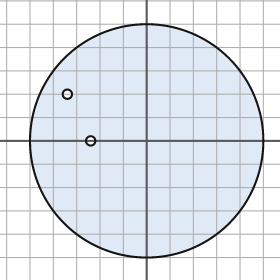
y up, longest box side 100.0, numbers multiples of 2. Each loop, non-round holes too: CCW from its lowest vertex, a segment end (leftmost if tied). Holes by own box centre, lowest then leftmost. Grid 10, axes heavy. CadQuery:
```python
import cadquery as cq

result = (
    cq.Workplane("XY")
    .moveTo(0.0, 0.0)
    .circle(50.0)
    .moveTo(-24.0, 0.0)
    .circle(2.0)
    .moveTo(-34.0, 20.0)
    .circle(2.0)
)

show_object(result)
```